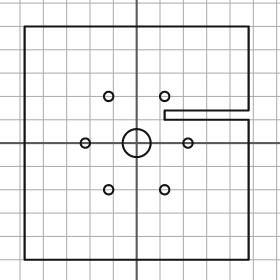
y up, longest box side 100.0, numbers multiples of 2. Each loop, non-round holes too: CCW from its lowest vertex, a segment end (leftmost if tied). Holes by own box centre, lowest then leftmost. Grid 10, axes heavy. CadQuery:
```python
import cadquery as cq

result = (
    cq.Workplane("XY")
    .moveTo(-48.0, -50.0)
    .lineTo(48.0, -50.0)
    .lineTo(48.0, 10.0)
    .lineTo(12.0, 10.0)
    .lineTo(12.0, 14.0)
    .lineTo(48.0, 14.0)
    .lineTo(48.0, 50.0)
    .lineTo(-48.0, 50.0)
    .close()
    .moveTo(-12.0, -20.0)
    .circle(2.0)
    .moveTo(12.0, -20.0)
    .circle(2.0)
    .moveTo(-22.0, 0.0)
    .circle(2.0)
    .moveTo(0.0, 0.0)
    .circle(6.0)
    .moveTo(22.0, 0.0)
    .circle(2.0)
    .moveTo(-12.0, 20.0)
    .circle(2.0)
    .moveTo(12.0, 20.0)
    .circle(2.0)
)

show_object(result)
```